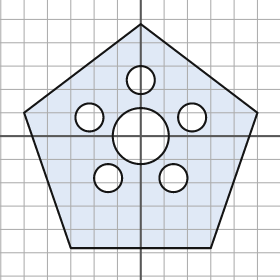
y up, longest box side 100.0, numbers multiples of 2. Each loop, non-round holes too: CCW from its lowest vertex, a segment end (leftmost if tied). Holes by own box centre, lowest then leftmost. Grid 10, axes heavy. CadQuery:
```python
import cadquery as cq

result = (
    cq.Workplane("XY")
    .moveTo(-30.0, -48.0)
    .lineTo(30.0, -48.0)
    .lineTo(50.0, 10.0)
    .lineTo(0.0, 48.0)
    .lineTo(-50.0, 10.0)
    .close()
    .moveTo(-14.0, -18.0)
    .circle(6.0)
    .moveTo(14.0, -18.0)
    .circle(6.0)
    .moveTo(0.0, 0.0)
    .circle(12.0)
    .moveTo(-22.0, 8.0)
    .circle(6.0)
    .moveTo(22.0, 8.0)
    .circle(6.0)
    .moveTo(0.0, 24.0)
    .circle(6.0)
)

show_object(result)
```